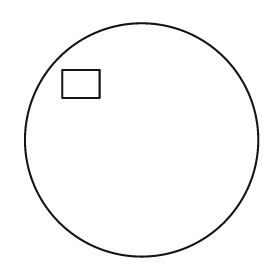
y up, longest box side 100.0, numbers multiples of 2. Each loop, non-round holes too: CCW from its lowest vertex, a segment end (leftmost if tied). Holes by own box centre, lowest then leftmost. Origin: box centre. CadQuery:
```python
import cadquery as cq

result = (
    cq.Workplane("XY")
    .moveTo(0.0, 0.0)
    .circle(50.0)
    .moveTo(-34.0, 18.0)
    .lineTo(-18.0, 18.0)
    .lineTo(-18.0, 30.0)
    .lineTo(-34.0, 30.0)
    .close()
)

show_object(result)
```